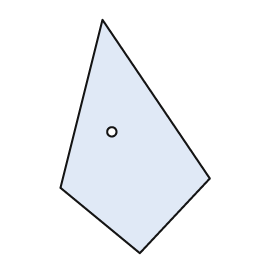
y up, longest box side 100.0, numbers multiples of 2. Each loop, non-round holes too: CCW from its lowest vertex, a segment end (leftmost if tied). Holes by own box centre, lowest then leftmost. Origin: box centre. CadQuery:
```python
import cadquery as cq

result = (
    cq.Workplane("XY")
    .moveTo(2.0, -50.0)
    .lineTo(32.0, -18.0)
    .lineTo(-14.0, 50.0)
    .lineTo(-32.0, -22.0)
    .close()
    .moveTo(-10.0, 2.0)
    .circle(2.0)
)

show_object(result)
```